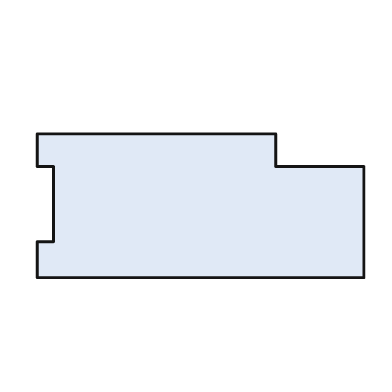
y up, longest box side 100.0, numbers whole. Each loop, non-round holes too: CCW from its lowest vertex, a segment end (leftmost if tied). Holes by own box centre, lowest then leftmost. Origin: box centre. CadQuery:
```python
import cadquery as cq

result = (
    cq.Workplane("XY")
    .moveTo(-50.0, -22.0)
    .lineTo(50.0, -22.0)
    .lineTo(50.0, 12.0)
    .lineTo(23.0, 12.0)
    .lineTo(23.0, 22.0)
    .lineTo(-50.0, 22.0)
    .lineTo(-50.0, 12.0)
    .lineTo(-45.0, 12.0)
    .lineTo(-45.0, -11.0)
    .lineTo(-50.0, -11.0)
    .close()
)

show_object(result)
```